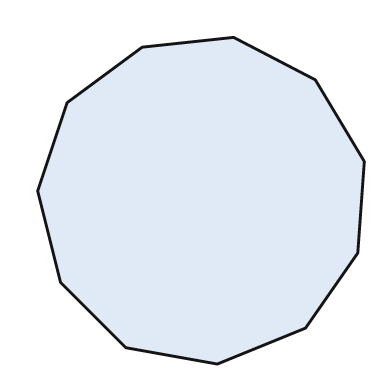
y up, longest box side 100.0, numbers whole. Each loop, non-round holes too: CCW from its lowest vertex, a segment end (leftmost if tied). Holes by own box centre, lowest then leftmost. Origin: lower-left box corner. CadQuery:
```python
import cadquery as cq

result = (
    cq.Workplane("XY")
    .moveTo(55.0, 0.0)
    .lineTo(82.0, 11.0)
    .lineTo(98.0, 34.0)
    .lineTo(100.0, 62.0)
    .lineTo(85.0, 87.0)
    .lineTo(60.0, 100.0)
    .lineTo(32.0, 97.0)
    .lineTo(9.0, 80.0)
    .lineTo(0.0, 53.0)
    .lineTo(7.0, 25.0)
    .lineTo(27.0, 5.0)
    .close()
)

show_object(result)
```